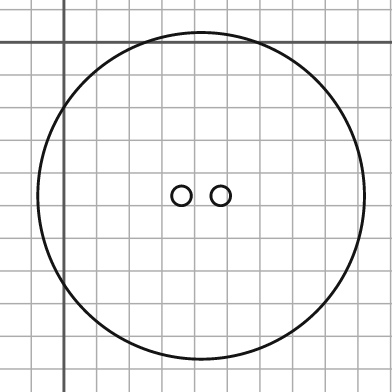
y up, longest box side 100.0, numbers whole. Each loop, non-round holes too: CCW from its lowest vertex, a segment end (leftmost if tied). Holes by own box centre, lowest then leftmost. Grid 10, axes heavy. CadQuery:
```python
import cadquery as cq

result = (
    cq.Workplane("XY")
    .moveTo(42.0, -47.0)
    .circle(50.0)
    .moveTo(36.0, -47.0)
    .circle(3.0)
    .moveTo(48.0, -47.0)
    .circle(3.0)
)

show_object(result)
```